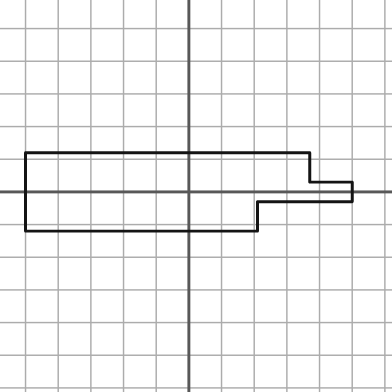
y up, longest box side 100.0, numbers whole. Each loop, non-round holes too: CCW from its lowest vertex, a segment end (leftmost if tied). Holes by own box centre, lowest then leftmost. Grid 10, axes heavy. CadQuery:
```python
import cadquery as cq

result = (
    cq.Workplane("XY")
    .moveTo(-50.0, -12.0)
    .lineTo(21.0, -12.0)
    .lineTo(21.0, -3.0)
    .lineTo(50.0, -3.0)
    .lineTo(50.0, 3.0)
    .lineTo(37.0, 3.0)
    .lineTo(37.0, 12.0)
    .lineTo(-50.0, 12.0)
    .close()
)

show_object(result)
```